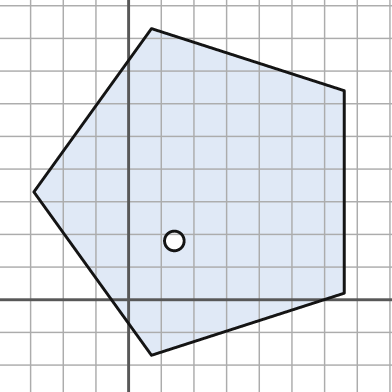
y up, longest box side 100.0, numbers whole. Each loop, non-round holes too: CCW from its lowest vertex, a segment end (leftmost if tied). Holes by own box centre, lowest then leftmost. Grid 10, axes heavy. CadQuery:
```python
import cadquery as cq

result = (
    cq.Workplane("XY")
    .moveTo(7.0, -17.0)
    .lineTo(66.0, 2.0)
    .lineTo(66.0, 64.0)
    .lineTo(7.0, 83.0)
    .lineTo(-29.0, 33.0)
    .close()
    .moveTo(14.0, 18.0)
    .circle(3.0)
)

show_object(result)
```